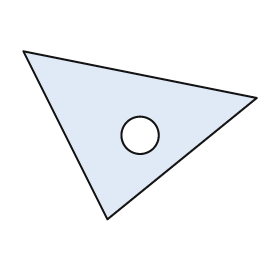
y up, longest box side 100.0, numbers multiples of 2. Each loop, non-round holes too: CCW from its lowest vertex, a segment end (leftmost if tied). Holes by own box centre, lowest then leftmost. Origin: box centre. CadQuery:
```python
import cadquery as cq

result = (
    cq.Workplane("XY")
    .moveTo(-14.0, -36.0)
    .lineTo(50.0, 16.0)
    .lineTo(-50.0, 36.0)
    .close()
    .moveTo(0.0, 0.0)
    .circle(8.0)
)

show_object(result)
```